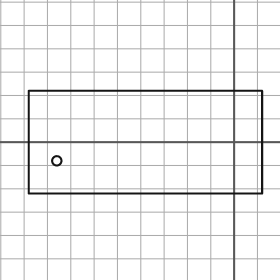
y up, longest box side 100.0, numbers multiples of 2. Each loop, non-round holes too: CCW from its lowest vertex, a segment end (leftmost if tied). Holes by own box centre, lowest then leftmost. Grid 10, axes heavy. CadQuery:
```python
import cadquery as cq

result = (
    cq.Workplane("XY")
    .moveTo(-88.0, -22.0)
    .lineTo(12.0, -22.0)
    .lineTo(12.0, 22.0)
    .lineTo(-88.0, 22.0)
    .close()
    .moveTo(-76.0, -8.0)
    .circle(2.0)
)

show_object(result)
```